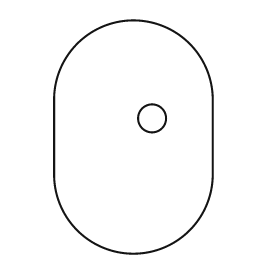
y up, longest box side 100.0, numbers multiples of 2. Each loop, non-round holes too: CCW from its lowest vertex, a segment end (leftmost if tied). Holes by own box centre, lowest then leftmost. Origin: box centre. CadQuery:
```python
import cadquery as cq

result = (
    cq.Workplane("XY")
    .moveTo(-34.0, -16.0)
    .threePointArc((0.0, -50.0), (34.0, -16.0))
    .lineTo(34.0, 16.0)
    .threePointArc((0.0, 50.0), (-34.0, 16.0))
    .close()
    .moveTo(8.0, 8.0)
    .circle(6.0)
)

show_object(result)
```